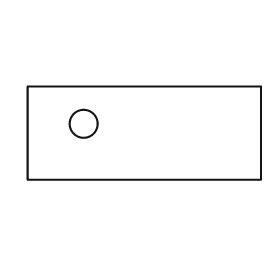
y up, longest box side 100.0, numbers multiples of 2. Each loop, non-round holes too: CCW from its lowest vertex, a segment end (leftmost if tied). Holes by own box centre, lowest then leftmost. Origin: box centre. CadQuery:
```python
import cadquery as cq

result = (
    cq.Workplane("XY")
    .moveTo(-50.0, -20.0)
    .lineTo(50.0, -20.0)
    .lineTo(50.0, 20.0)
    .lineTo(-50.0, 20.0)
    .close()
    .moveTo(-26.0, 4.0)
    .circle(6.0)
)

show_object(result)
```